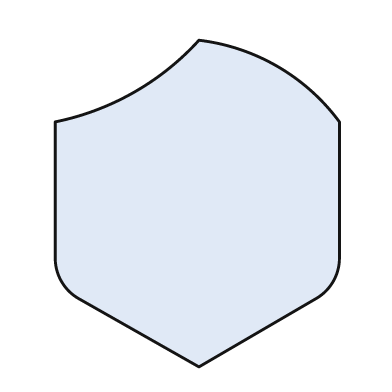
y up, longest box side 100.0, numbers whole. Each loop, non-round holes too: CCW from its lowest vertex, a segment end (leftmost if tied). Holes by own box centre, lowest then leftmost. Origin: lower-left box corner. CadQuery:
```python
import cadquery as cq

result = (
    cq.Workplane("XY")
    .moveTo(44.0, 0.0)
    .lineTo(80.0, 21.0)
    .threePointArc((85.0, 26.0), (87.0, 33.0))
    .lineTo(87.0, 75.0)
    .threePointArc((68.0, 92.0), (44.0, 100.0))
    .threePointArc((24.0, 84.0), (0.0, 75.0))
    .lineTo(0.0, 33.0)
    .threePointArc((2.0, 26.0), (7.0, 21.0))
    .close()
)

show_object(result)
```